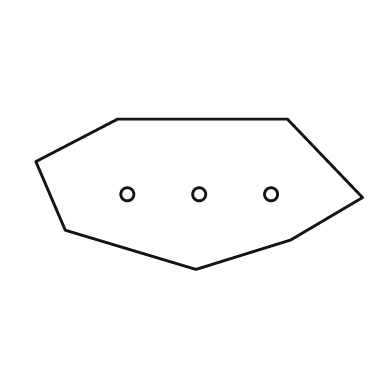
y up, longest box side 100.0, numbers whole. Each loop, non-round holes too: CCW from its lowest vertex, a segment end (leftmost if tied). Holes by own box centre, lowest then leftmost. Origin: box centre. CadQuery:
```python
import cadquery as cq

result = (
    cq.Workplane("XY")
    .moveTo(-1.0, -23.0)
    .lineTo(28.0, -14.0)
    .lineTo(50.0, -1.0)
    .lineTo(27.0, 23.0)
    .lineTo(-25.0, 23.0)
    .lineTo(-50.0, 10.0)
    .lineTo(-41.0, -11.0)
    .close()
    .moveTo(-22.0, 0.0)
    .circle(2.0)
    .moveTo(0.0, 0.0)
    .circle(2.0)
    .moveTo(22.0, 0.0)
    .circle(2.0)
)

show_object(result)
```